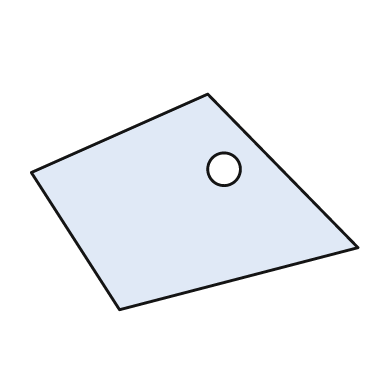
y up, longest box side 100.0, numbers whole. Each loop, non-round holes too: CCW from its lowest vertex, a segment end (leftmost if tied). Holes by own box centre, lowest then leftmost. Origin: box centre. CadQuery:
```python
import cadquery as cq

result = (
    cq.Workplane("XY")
    .moveTo(-23.0, -33.0)
    .lineTo(50.0, -14.0)
    .lineTo(4.0, 33.0)
    .lineTo(-50.0, 9.0)
    .close()
    .moveTo(9.0, 10.0)
    .circle(5.0)
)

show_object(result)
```